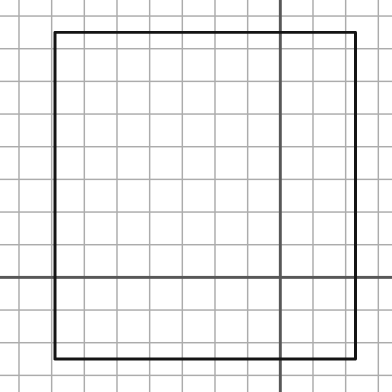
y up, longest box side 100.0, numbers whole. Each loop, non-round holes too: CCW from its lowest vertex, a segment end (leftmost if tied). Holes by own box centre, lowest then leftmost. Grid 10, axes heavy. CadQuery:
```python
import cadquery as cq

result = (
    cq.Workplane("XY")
    .moveTo(-69.0, -25.0)
    .lineTo(23.0, -25.0)
    .lineTo(23.0, 75.0)
    .lineTo(-69.0, 75.0)
    .close()
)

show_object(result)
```